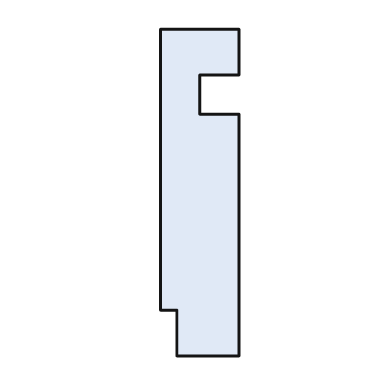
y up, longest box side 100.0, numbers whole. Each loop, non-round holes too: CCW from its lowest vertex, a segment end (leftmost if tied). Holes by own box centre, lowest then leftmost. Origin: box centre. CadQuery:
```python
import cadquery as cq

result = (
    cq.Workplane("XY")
    .moveTo(-7.0, -50.0)
    .lineTo(12.0, -50.0)
    .lineTo(12.0, 24.0)
    .lineTo(0.0, 24.0)
    .lineTo(0.0, 36.0)
    .lineTo(12.0, 36.0)
    .lineTo(12.0, 50.0)
    .lineTo(-12.0, 50.0)
    .lineTo(-12.0, -36.0)
    .lineTo(-7.0, -36.0)
    .close()
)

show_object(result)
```